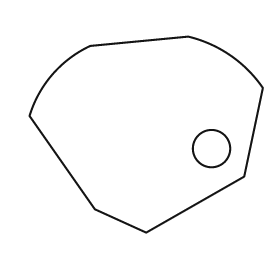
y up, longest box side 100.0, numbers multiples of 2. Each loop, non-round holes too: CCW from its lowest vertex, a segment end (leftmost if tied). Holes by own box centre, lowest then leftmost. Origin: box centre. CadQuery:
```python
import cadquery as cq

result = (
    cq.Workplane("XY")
    .moveTo(0.0, -42.0)
    .lineTo(42.0, -18.0)
    .lineTo(50.0, 20.0)
    .threePointArc((36.0, 34.0), (18.0, 42.0))
    .lineTo(-24.0, 38.0)
    .threePointArc((-40.0, 26.0), (-50.0, 8.0))
    .lineTo(-22.0, -32.0)
    .close()
    .moveTo(28.0, -6.0)
    .circle(8.0)
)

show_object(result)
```